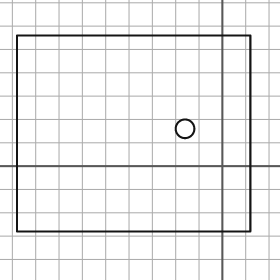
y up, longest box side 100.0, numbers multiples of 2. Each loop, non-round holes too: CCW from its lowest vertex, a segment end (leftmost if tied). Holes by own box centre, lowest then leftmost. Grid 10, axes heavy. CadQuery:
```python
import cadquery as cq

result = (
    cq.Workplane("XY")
    .moveTo(-88.0, -28.0)
    .lineTo(12.0, -28.0)
    .lineTo(12.0, 56.0)
    .lineTo(-88.0, 56.0)
    .close()
    .moveTo(-16.0, 16.0)
    .circle(4.0)
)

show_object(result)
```